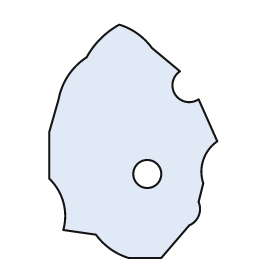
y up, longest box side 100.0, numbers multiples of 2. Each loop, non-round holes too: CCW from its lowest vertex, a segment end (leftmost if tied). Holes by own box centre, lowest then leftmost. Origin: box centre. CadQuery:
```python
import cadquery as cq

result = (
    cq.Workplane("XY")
    .moveTo(-2.0, -50.0)
    .lineTo(12.0, -50.0)
    .lineTo(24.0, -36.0)
    .threePointArc((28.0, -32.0), (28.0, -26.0))
    .lineTo(30.0, -18.0)
    .threePointArc((30.0, -8.0), (36.0, 0.0))
    .lineTo(28.0, 18.0)
    .threePointArc((18.0, 20.0), (20.0, 30.0))
    .lineTo(8.0, 40.0)
    .threePointArc((2.0, 46.0), (-6.0, 50.0))
    .threePointArc((-14.0, 44.0), (-20.0, 36.0))
    .threePointArc((-28.0, 28.0), (-32.0, 18.0))
    .lineTo(-36.0, 4.0)
    .lineTo(-36.0, -16.0)
    .threePointArc((-30.0, -26.0), (-30.0, -38.0))
    .lineTo(-16.0, -40.0)
    .threePointArc((-10.0, -46.0), (-2.0, -50.0))
    .close()
    .moveTo(6.0, -14.0)
    .circle(6.0)
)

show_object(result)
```